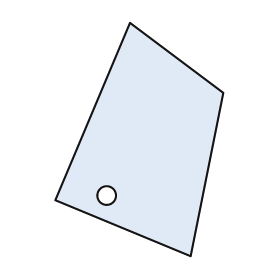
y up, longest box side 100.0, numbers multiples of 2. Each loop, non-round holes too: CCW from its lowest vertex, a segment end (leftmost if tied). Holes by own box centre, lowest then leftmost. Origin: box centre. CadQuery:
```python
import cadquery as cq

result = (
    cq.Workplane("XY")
    .moveTo(22.0, -50.0)
    .lineTo(36.0, 20.0)
    .lineTo(-4.0, 50.0)
    .lineTo(-36.0, -26.0)
    .close()
    .moveTo(-14.0, -24.0)
    .circle(4.0)
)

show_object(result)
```